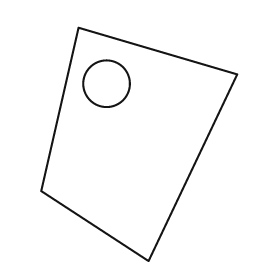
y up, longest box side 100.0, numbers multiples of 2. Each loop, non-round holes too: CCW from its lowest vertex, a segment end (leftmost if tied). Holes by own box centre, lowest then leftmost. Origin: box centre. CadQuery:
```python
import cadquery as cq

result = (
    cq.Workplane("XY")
    .moveTo(4.0, -50.0)
    .lineTo(42.0, 30.0)
    .lineTo(-26.0, 50.0)
    .lineTo(-42.0, -20.0)
    .close()
    .moveTo(-14.0, 26.0)
    .circle(10.0)
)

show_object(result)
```